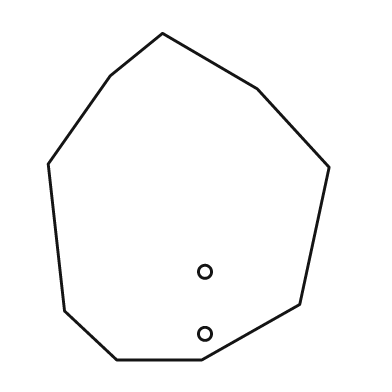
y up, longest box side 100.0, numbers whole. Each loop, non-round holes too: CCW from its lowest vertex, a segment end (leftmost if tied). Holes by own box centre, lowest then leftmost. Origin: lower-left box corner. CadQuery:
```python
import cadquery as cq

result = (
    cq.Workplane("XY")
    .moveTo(21.0, 0.0)
    .lineTo(47.0, 0.0)
    .lineTo(77.0, 17.0)
    .lineTo(86.0, 59.0)
    .lineTo(64.0, 83.0)
    .lineTo(35.0, 100.0)
    .lineTo(19.0, 87.0)
    .lineTo(0.0, 60.0)
    .lineTo(5.0, 15.0)
    .close()
    .moveTo(48.0, 8.0)
    .circle(2.0)
    .moveTo(48.0, 27.0)
    .circle(2.0)
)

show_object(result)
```